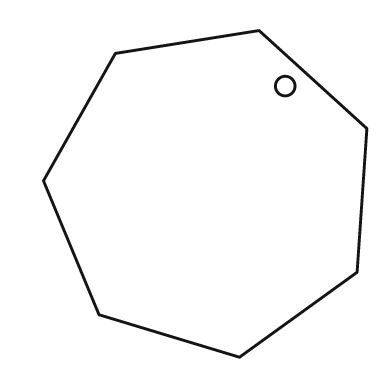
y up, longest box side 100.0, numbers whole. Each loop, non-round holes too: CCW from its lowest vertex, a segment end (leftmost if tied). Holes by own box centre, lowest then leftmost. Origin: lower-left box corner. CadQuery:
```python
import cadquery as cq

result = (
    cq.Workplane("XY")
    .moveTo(60.0, 0.0)
    .lineTo(96.0, 26.0)
    .lineTo(99.0, 70.0)
    .lineTo(66.0, 100.0)
    .lineTo(22.0, 93.0)
    .lineTo(0.0, 54.0)
    .lineTo(17.0, 13.0)
    .close()
    .moveTo(74.0, 83.0)
    .circle(3.0)
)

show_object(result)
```